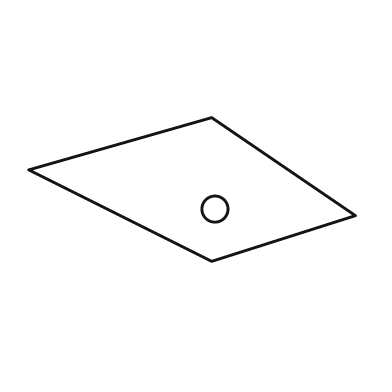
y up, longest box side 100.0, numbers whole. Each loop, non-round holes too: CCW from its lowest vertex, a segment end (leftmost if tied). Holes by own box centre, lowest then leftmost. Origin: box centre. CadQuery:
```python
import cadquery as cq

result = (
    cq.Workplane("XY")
    .moveTo(6.0, -22.0)
    .lineTo(50.0, -8.0)
    .lineTo(6.0, 22.0)
    .lineTo(-50.0, 6.0)
    .close()
    .moveTo(7.0, -6.0)
    .circle(4.0)
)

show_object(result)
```